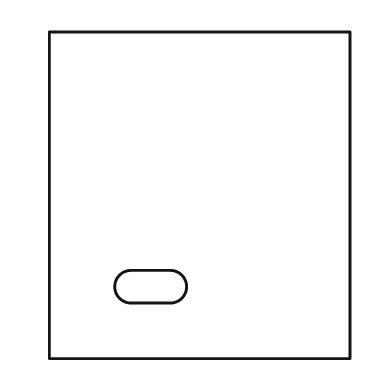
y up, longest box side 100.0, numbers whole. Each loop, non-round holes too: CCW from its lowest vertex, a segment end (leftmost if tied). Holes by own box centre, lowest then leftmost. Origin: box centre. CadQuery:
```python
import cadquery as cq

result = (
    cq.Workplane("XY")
    .moveTo(-46.0, -50.0)
    .lineTo(46.0, -50.0)
    .lineTo(46.0, 50.0)
    .lineTo(-46.0, 50.0)
    .close()
    .moveTo(-21.0, -33.0)
    .lineTo(-9.0, -33.0)
    .threePointArc((-4.0, -28.0), (-9.0, -23.0))
    .lineTo(-21.0, -23.0)
    .threePointArc((-26.0, -28.0), (-21.0, -33.0))
    .close()
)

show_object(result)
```